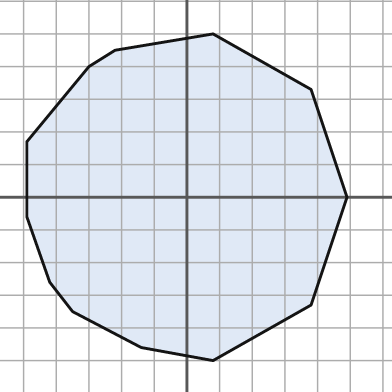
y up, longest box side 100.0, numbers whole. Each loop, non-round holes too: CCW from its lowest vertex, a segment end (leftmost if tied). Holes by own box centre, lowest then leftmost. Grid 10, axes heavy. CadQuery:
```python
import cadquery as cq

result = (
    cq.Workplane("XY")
    .moveTo(8.0, -50.0)
    .lineTo(38.0, -33.0)
    .lineTo(49.0, 0.0)
    .lineTo(38.0, 33.0)
    .lineTo(8.0, 50.0)
    .lineTo(-22.0, 45.0)
    .lineTo(-30.0, 40.0)
    .lineTo(-49.0, 17.0)
    .lineTo(-49.0, -6.0)
    .lineTo(-42.0, -26.0)
    .lineTo(-35.0, -35.0)
    .lineTo(-14.0, -46.0)
    .close()
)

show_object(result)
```